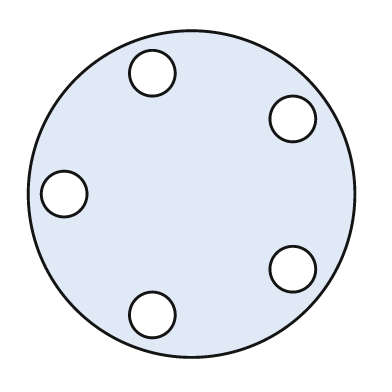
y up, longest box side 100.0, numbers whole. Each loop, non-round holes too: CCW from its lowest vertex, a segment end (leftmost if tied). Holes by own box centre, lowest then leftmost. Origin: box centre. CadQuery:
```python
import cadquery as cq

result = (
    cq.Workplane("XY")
    .moveTo(0.0, 0.0)
    .circle(50.0)
    .moveTo(-12.0, -37.0)
    .circle(7.0)
    .moveTo(31.0, -23.0)
    .circle(7.0)
    .moveTo(-39.0, 0.0)
    .circle(7.0)
    .moveTo(31.0, 23.0)
    .circle(7.0)
    .moveTo(-12.0, 37.0)
    .circle(7.0)
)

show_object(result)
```